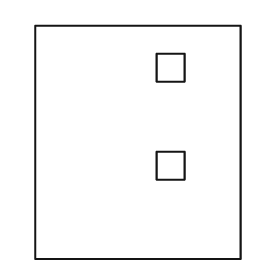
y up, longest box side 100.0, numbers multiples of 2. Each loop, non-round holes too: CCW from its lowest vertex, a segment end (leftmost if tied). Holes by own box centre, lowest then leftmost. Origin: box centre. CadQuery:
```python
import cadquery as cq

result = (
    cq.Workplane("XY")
    .moveTo(-44.0, -50.0)
    .lineTo(44.0, -50.0)
    .lineTo(44.0, 50.0)
    .lineTo(-44.0, 50.0)
    .close()
    .moveTo(8.0, -16.0)
    .lineTo(20.0, -16.0)
    .lineTo(20.0, -4.0)
    .lineTo(8.0, -4.0)
    .close()
    .moveTo(8.0, 26.0)
    .lineTo(20.0, 26.0)
    .lineTo(20.0, 38.0)
    .lineTo(8.0, 38.0)
    .close()
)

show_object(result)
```